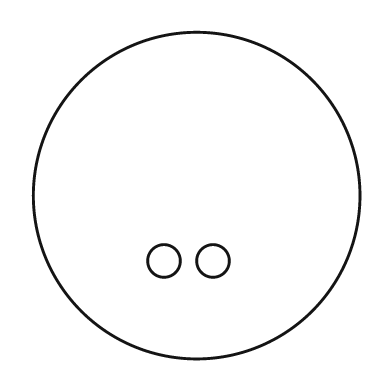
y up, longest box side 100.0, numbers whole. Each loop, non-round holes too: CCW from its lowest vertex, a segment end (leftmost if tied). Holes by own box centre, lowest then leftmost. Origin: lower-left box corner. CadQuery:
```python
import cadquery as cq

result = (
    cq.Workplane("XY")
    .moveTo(50.0, 50.0)
    .circle(50.0)
    .moveTo(40.0, 30.0)
    .circle(5.0)
    .moveTo(55.0, 30.0)
    .circle(5.0)
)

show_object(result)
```